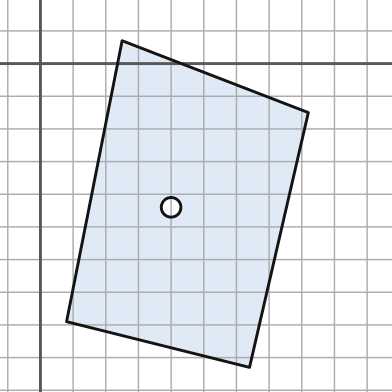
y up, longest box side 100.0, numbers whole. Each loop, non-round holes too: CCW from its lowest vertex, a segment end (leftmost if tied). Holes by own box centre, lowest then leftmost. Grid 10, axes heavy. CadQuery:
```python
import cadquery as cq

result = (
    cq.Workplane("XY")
    .moveTo(64.0, -93.0)
    .lineTo(82.0, -15.0)
    .lineTo(25.0, 7.0)
    .lineTo(8.0, -79.0)
    .close()
    .moveTo(40.0, -44.0)
    .circle(3.0)
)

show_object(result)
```